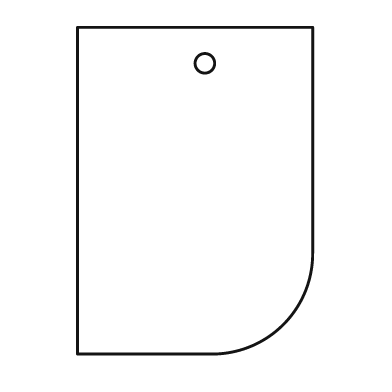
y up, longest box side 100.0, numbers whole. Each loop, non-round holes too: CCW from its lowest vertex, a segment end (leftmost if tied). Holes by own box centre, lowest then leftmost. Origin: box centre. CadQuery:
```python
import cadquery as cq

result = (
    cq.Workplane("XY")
    .moveTo(-36.0, -50.0)
    .lineTo(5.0, -50.0)
    .threePointArc((27.0, -41.0), (36.0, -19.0))
    .lineTo(36.0, 50.0)
    .lineTo(-36.0, 50.0)
    .close()
    .moveTo(3.0, 39.0)
    .circle(3.0)
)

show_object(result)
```